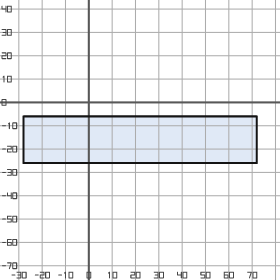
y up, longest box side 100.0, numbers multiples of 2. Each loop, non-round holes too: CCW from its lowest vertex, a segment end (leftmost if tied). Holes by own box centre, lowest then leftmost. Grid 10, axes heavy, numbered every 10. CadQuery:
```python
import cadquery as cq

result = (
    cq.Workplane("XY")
    .moveTo(-28.0, -26.0)
    .lineTo(72.0, -26.0)
    .lineTo(72.0, -6.0)
    .lineTo(-28.0, -6.0)
    .close()
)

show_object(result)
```